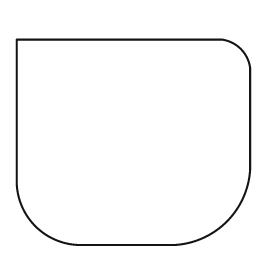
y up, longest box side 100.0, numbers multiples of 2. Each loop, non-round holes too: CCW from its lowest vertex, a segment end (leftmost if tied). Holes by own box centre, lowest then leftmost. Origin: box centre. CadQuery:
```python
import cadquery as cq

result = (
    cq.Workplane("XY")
    .moveTo(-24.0, -44.0)
    .lineTo(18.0, -44.0)
    .threePointArc((40.0, -34.0), (50.0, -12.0))
    .lineTo(50.0, 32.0)
    .threePointArc((46.0, 40.0), (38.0, 44.0))
    .lineTo(-50.0, 44.0)
    .lineTo(-50.0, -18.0)
    .threePointArc((-42.0, -36.0), (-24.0, -44.0))
    .close()
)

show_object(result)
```